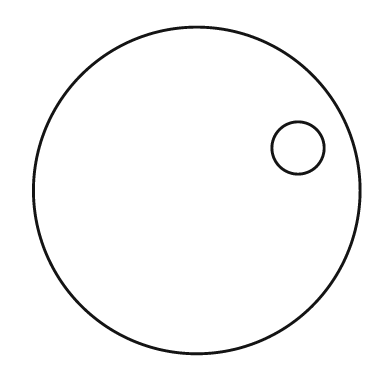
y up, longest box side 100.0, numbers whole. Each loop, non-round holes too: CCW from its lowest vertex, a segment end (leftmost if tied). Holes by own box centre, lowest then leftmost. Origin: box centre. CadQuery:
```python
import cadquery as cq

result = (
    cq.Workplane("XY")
    .moveTo(0.0, 0.0)
    .circle(50.0)
    .moveTo(31.0, 13.0)
    .circle(8.0)
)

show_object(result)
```